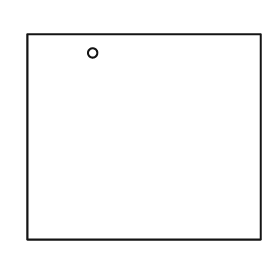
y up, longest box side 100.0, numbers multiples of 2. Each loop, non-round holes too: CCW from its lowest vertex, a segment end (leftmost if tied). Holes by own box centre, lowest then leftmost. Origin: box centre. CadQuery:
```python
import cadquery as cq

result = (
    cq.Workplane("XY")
    .moveTo(-50.0, -44.0)
    .lineTo(50.0, -44.0)
    .lineTo(50.0, 44.0)
    .lineTo(-50.0, 44.0)
    .close()
    .moveTo(-22.0, 36.0)
    .circle(2.0)
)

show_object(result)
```